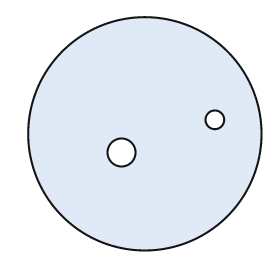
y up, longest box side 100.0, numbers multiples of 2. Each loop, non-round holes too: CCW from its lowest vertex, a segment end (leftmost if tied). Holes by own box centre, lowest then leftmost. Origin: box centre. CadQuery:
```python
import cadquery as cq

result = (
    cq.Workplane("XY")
    .moveTo(0.0, 0.0)
    .circle(50.0)
    .moveTo(-10.0, -8.0)
    .circle(6.0)
    .moveTo(30.0, 6.0)
    .circle(4.0)
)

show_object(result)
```